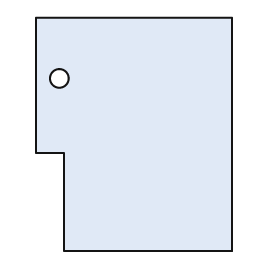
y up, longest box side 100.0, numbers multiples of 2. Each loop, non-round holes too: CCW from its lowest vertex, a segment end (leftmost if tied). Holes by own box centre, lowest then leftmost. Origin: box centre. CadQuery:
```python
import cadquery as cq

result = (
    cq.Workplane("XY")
    .moveTo(-30.0, -50.0)
    .lineTo(42.0, -50.0)
    .lineTo(42.0, 50.0)
    .lineTo(-42.0, 50.0)
    .lineTo(-42.0, -8.0)
    .lineTo(-30.0, -8.0)
    .close()
    .moveTo(-32.0, 24.0)
    .circle(4.0)
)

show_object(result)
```